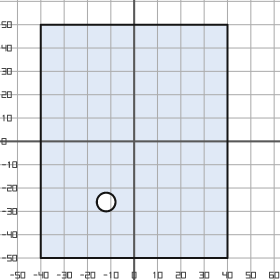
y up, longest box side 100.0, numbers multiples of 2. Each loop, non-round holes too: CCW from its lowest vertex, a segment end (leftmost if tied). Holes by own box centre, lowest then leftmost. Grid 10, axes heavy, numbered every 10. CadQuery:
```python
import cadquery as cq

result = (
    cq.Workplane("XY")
    .moveTo(-40.0, -50.0)
    .lineTo(40.0, -50.0)
    .lineTo(40.0, 50.0)
    .lineTo(-40.0, 50.0)
    .close()
    .moveTo(-12.0, -26.0)
    .circle(4.0)
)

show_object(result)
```